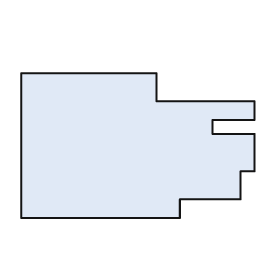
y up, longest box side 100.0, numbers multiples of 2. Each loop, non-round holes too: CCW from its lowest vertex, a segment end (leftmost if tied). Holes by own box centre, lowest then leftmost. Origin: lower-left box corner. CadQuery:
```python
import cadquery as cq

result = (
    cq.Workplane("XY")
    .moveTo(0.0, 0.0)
    .lineTo(68.0, 0.0)
    .lineTo(68.0, 8.0)
    .lineTo(94.0, 8.0)
    .lineTo(94.0, 20.0)
    .lineTo(100.0, 20.0)
    .lineTo(100.0, 36.0)
    .lineTo(82.0, 36.0)
    .lineTo(82.0, 42.0)
    .lineTo(100.0, 42.0)
    .lineTo(100.0, 50.0)
    .lineTo(58.0, 50.0)
    .lineTo(58.0, 62.0)
    .lineTo(0.0, 62.0)
    .close()
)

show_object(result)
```